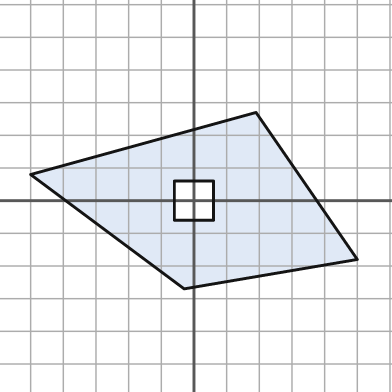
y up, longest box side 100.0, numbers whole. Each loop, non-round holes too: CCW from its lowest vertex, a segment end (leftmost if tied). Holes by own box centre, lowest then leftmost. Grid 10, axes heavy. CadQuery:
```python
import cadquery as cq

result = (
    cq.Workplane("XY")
    .moveTo(-3.0, -27.0)
    .lineTo(50.0, -18.0)
    .lineTo(19.0, 27.0)
    .lineTo(-50.0, 8.0)
    .close()
    .moveTo(-6.0, -6.0)
    .lineTo(6.0, -6.0)
    .lineTo(6.0, 6.0)
    .lineTo(-6.0, 6.0)
    .close()
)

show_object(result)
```